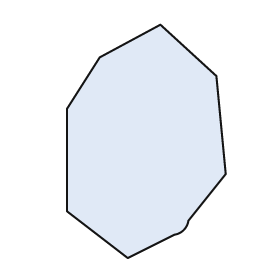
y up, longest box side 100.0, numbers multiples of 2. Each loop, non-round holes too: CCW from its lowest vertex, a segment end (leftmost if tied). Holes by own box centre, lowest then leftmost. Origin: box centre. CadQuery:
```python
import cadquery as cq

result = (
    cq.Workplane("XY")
    .moveTo(-8.0, -50.0)
    .lineTo(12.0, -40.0)
    .threePointArc((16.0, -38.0), (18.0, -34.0))
    .lineTo(34.0, -14.0)
    .lineTo(30.0, 28.0)
    .lineTo(6.0, 50.0)
    .lineTo(-20.0, 36.0)
    .lineTo(-34.0, 14.0)
    .lineTo(-34.0, -30.0)
    .close()
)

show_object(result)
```